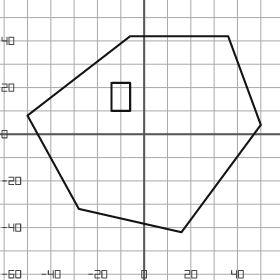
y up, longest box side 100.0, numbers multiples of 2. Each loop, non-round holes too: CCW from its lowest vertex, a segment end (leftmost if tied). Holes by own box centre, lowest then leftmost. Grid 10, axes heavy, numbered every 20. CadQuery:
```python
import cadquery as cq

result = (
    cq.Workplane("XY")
    .moveTo(16.0, -42.0)
    .lineTo(50.0, 4.0)
    .lineTo(36.0, 42.0)
    .lineTo(-6.0, 42.0)
    .lineTo(-50.0, 8.0)
    .lineTo(-28.0, -32.0)
    .close()
    .moveTo(-14.0, 10.0)
    .lineTo(-6.0, 10.0)
    .lineTo(-6.0, 22.0)
    .lineTo(-14.0, 22.0)
    .close()
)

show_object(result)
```